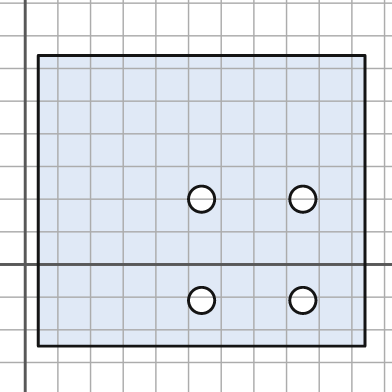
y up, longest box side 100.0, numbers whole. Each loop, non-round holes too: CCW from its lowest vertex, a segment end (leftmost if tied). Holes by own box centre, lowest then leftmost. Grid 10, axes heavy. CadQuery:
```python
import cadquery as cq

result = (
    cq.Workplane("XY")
    .moveTo(4.0, -25.0)
    .lineTo(104.0, -25.0)
    .lineTo(104.0, 64.0)
    .lineTo(4.0, 64.0)
    .close()
    .moveTo(54.0, -11.0)
    .circle(4.0)
    .moveTo(85.0, -11.0)
    .circle(4.0)
    .moveTo(54.0, 20.0)
    .circle(4.0)
    .moveTo(85.0, 20.0)
    .circle(4.0)
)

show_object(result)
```